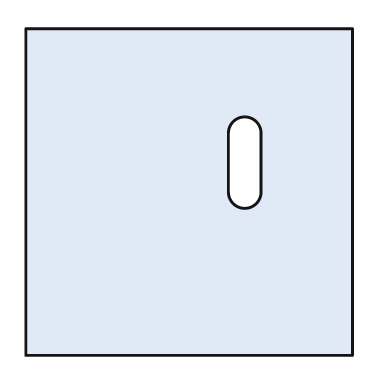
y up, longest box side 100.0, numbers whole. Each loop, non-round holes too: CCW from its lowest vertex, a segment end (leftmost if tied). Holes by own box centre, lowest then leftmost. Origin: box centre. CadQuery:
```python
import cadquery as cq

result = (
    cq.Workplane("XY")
    .moveTo(-50.0, -50.0)
    .lineTo(50.0, -50.0)
    .lineTo(50.0, 50.0)
    .lineTo(-50.0, 50.0)
    .close()
    .moveTo(12.0, 0.0)
    .threePointArc((17.0, -5.0), (22.0, 0.0))
    .lineTo(22.0, 18.0)
    .threePointArc((17.0, 23.0), (12.0, 18.0))
    .close()
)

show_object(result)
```